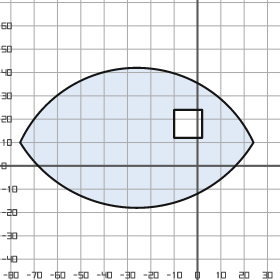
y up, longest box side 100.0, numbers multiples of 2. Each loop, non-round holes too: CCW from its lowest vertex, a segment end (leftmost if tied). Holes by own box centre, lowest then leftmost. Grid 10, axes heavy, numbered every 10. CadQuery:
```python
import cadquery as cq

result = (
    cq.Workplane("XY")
    .moveTo(-76.0, 10.0)
    .threePointArc((-26.0, -18.0), (24.0, 10.0))
    .threePointArc((-26.0, 42.0), (-76.0, 10.0))
    .close()
    .moveTo(-10.0, 12.0)
    .lineTo(2.0, 12.0)
    .lineTo(2.0, 24.0)
    .lineTo(-10.0, 24.0)
    .close()
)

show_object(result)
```